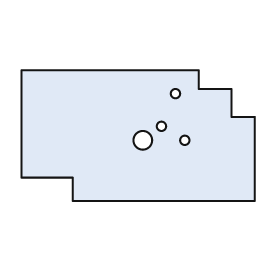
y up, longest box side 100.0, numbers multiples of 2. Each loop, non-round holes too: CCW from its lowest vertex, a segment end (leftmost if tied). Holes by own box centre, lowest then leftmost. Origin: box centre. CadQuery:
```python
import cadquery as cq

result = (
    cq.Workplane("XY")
    .moveTo(-28.0, -28.0)
    .lineTo(50.0, -28.0)
    .lineTo(50.0, 8.0)
    .lineTo(40.0, 8.0)
    .lineTo(40.0, 20.0)
    .lineTo(26.0, 20.0)
    .lineTo(26.0, 28.0)
    .lineTo(-50.0, 28.0)
    .lineTo(-50.0, -18.0)
    .lineTo(-28.0, -18.0)
    .close()
    .moveTo(2.0, -2.0)
    .circle(4.0)
    .moveTo(20.0, -2.0)
    .circle(2.0)
    .moveTo(10.0, 4.0)
    .circle(2.0)
    .moveTo(16.0, 18.0)
    .circle(2.0)
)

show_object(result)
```